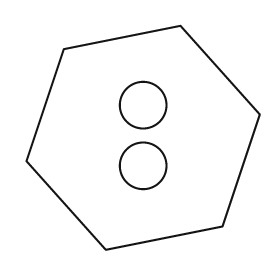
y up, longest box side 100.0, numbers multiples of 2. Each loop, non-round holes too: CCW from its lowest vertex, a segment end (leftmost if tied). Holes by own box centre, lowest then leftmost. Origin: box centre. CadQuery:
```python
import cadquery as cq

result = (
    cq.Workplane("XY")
    .moveTo(-16.0, -48.0)
    .lineTo(34.0, -38.0)
    .lineTo(50.0, 10.0)
    .lineTo(16.0, 48.0)
    .lineTo(-34.0, 38.0)
    .lineTo(-50.0, -10.0)
    .close()
    .moveTo(0.0, -12.0)
    .circle(10.0)
    .moveTo(0.0, 14.0)
    .circle(10.0)
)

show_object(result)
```